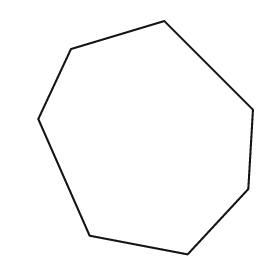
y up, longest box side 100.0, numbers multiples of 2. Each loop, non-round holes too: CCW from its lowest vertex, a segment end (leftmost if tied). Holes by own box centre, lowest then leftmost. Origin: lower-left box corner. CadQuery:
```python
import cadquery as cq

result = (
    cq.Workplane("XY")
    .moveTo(64.0, 0.0)
    .lineTo(90.0, 28.0)
    .lineTo(92.0, 62.0)
    .lineTo(54.0, 100.0)
    .lineTo(14.0, 88.0)
    .lineTo(0.0, 58.0)
    .lineTo(22.0, 8.0)
    .close()
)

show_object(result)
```